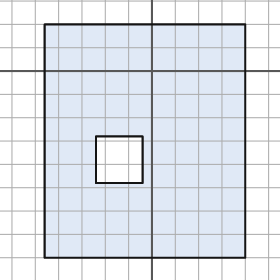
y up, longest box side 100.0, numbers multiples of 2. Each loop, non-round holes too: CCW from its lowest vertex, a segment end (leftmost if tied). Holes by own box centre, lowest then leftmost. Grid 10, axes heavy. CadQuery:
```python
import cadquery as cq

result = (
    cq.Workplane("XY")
    .moveTo(-46.0, -80.0)
    .lineTo(40.0, -80.0)
    .lineTo(40.0, 20.0)
    .lineTo(-46.0, 20.0)
    .close()
    .moveTo(-24.0, -48.0)
    .lineTo(-4.0, -48.0)
    .lineTo(-4.0, -28.0)
    .lineTo(-24.0, -28.0)
    .close()
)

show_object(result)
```